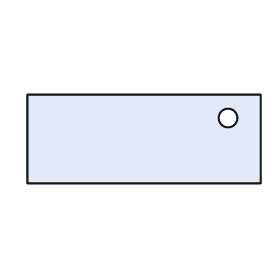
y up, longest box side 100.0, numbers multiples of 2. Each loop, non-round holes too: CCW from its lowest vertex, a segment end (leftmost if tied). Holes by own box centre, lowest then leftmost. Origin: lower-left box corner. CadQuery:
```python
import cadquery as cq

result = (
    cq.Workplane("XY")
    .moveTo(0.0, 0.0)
    .lineTo(100.0, 0.0)
    .lineTo(100.0, 38.0)
    .lineTo(0.0, 38.0)
    .close()
    .moveTo(86.0, 28.0)
    .circle(4.0)
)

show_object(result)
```